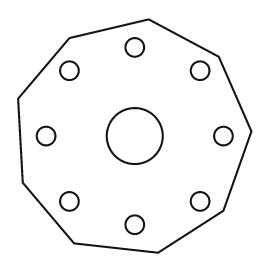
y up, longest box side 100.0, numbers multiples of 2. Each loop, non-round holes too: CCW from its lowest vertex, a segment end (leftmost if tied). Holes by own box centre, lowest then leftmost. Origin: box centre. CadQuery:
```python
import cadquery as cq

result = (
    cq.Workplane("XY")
    .moveTo(10.0, -50.0)
    .lineTo(38.0, -32.0)
    .lineTo(50.0, 2.0)
    .lineTo(36.0, 34.0)
    .lineTo(6.0, 50.0)
    .lineTo(-28.0, 42.0)
    .lineTo(-50.0, 16.0)
    .lineTo(-48.0, -20.0)
    .lineTo(-26.0, -46.0)
    .close()
    .moveTo(0.0, -38.0)
    .circle(4.0)
    .moveTo(-28.0, -28.0)
    .circle(4.0)
    .moveTo(28.0, -28.0)
    .circle(4.0)
    .moveTo(-38.0, 0.0)
    .circle(4.0)
    .moveTo(0.0, 0.0)
    .circle(12.0)
    .moveTo(38.0, 0.0)
    .circle(4.0)
    .moveTo(-28.0, 28.0)
    .circle(4.0)
    .moveTo(28.0, 28.0)
    .circle(4.0)
    .moveTo(0.0, 38.0)
    .circle(4.0)
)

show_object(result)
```